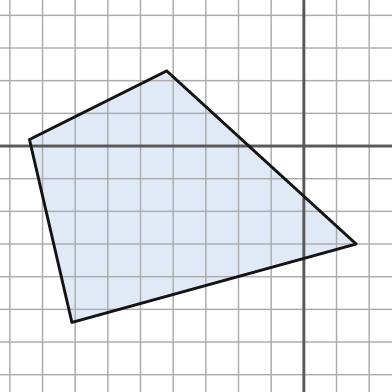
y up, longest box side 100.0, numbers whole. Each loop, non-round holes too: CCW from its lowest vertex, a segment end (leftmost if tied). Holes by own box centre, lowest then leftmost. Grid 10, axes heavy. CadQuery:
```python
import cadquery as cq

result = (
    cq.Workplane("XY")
    .moveTo(-71.0, -54.0)
    .lineTo(16.0, -30.0)
    .lineTo(-42.0, 23.0)
    .lineTo(-84.0, 2.0)
    .close()
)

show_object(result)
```